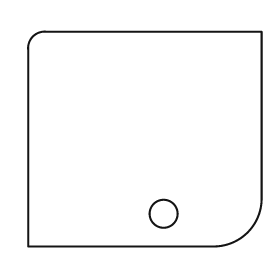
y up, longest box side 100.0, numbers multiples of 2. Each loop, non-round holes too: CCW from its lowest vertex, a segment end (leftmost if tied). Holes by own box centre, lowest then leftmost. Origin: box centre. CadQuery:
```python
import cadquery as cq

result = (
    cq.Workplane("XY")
    .moveTo(-50.0, -46.0)
    .lineTo(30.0, -46.0)
    .threePointArc((44.0, -40.0), (50.0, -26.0))
    .lineTo(50.0, 46.0)
    .lineTo(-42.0, 46.0)
    .threePointArc((-48.0, 44.0), (-50.0, 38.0))
    .close()
    .moveTo(8.0, -32.0)
    .circle(6.0)
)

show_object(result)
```